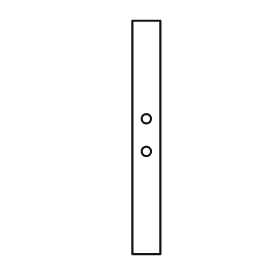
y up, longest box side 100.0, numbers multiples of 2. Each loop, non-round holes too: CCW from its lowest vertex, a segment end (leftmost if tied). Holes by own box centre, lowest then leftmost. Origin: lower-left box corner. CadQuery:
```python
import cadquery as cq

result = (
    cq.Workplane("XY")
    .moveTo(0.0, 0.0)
    .lineTo(12.0, 0.0)
    .lineTo(12.0, 100.0)
    .lineTo(0.0, 100.0)
    .close()
    .moveTo(6.0, 44.0)
    .circle(2.0)
    .moveTo(6.0, 58.0)
    .circle(2.0)
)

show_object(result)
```